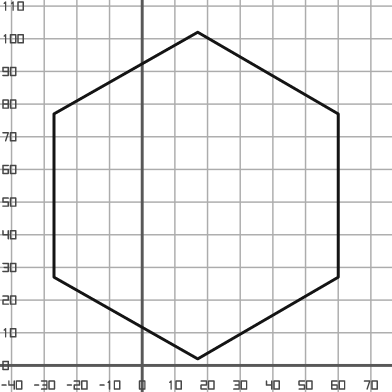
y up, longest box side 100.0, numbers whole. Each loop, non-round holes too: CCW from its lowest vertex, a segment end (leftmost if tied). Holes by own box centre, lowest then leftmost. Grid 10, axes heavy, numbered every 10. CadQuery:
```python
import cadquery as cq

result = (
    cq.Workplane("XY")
    .moveTo(17.0, 2.0)
    .lineTo(60.0, 27.0)
    .lineTo(60.0, 77.0)
    .lineTo(17.0, 102.0)
    .lineTo(-27.0, 77.0)
    .lineTo(-27.0, 27.0)
    .close()
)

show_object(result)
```